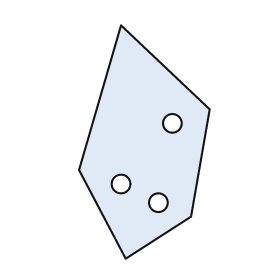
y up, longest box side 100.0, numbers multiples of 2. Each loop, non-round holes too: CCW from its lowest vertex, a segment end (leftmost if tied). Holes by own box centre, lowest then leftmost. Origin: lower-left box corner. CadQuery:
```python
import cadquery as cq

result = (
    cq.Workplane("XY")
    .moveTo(20.0, 0.0)
    .lineTo(48.0, 18.0)
    .lineTo(56.0, 64.0)
    .lineTo(18.0, 100.0)
    .lineTo(0.0, 38.0)
    .close()
    .moveTo(34.0, 24.0)
    .circle(4.0)
    .moveTo(18.0, 32.0)
    .circle(4.0)
    .moveTo(40.0, 58.0)
    .circle(4.0)
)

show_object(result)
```